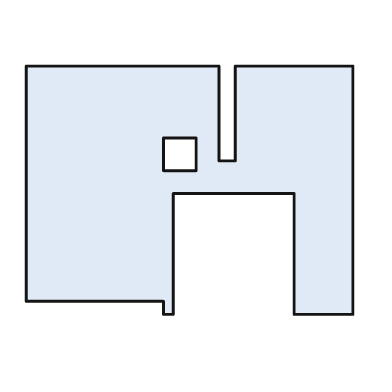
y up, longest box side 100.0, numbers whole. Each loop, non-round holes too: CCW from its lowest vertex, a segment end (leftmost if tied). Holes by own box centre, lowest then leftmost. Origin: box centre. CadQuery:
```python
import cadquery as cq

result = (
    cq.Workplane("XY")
    .moveTo(-8.0, -38.0)
    .lineTo(-5.0, -38.0)
    .lineTo(-5.0, -1.0)
    .lineTo(32.0, -1.0)
    .lineTo(32.0, -38.0)
    .lineTo(50.0, -38.0)
    .lineTo(50.0, 38.0)
    .lineTo(14.0, 38.0)
    .lineTo(14.0, 9.0)
    .lineTo(9.0, 9.0)
    .lineTo(9.0, 38.0)
    .lineTo(-50.0, 38.0)
    .lineTo(-50.0, -34.0)
    .lineTo(-8.0, -34.0)
    .close()
    .moveTo(-8.0, 6.0)
    .lineTo(2.0, 6.0)
    .lineTo(2.0, 16.0)
    .lineTo(-8.0, 16.0)
    .close()
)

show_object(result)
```